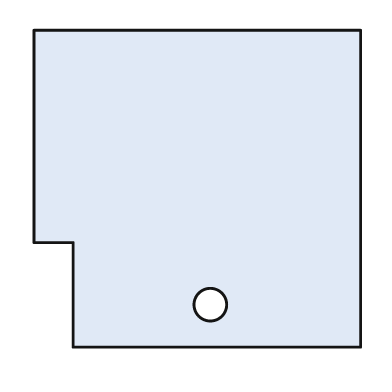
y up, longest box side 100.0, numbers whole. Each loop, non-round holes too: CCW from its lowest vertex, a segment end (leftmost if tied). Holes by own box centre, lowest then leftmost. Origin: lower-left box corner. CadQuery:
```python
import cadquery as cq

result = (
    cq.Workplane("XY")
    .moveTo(12.0, 0.0)
    .lineTo(100.0, 0.0)
    .lineTo(100.0, 97.0)
    .lineTo(0.0, 97.0)
    .lineTo(0.0, 32.0)
    .lineTo(12.0, 32.0)
    .close()
    .moveTo(54.0, 13.0)
    .circle(5.0)
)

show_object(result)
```